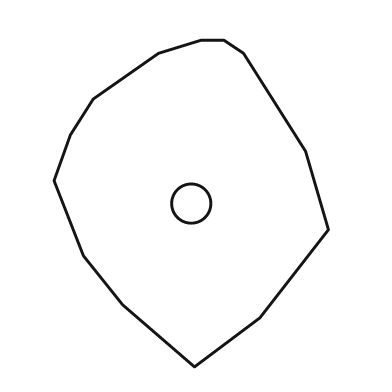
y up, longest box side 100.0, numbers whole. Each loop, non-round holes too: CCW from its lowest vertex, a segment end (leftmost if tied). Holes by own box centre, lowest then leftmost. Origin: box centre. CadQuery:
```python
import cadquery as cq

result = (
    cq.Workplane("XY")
    .moveTo(1.0, -50.0)
    .lineTo(21.0, -35.0)
    .lineTo(42.0, -8.0)
    .lineTo(35.0, 16.0)
    .lineTo(16.0, 46.0)
    .lineTo(10.0, 50.0)
    .lineTo(3.0, 50.0)
    .lineTo(-10.0, 46.0)
    .lineTo(-30.0, 32.0)
    .lineTo(-37.0, 21.0)
    .lineTo(-42.0, 7.0)
    .lineTo(-33.0, -16.0)
    .lineTo(-21.0, -31.0)
    .close()
    .moveTo(0.0, 0.0)
    .circle(6.0)
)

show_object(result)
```